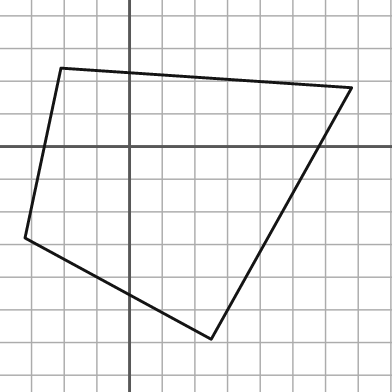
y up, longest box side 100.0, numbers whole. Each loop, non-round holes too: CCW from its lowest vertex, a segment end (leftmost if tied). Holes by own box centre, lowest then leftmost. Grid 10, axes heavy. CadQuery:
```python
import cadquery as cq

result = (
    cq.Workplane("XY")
    .moveTo(25.0, -59.0)
    .lineTo(68.0, 18.0)
    .lineTo(-21.0, 24.0)
    .lineTo(-32.0, -28.0)
    .close()
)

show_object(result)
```